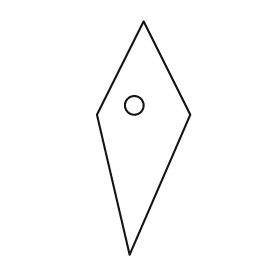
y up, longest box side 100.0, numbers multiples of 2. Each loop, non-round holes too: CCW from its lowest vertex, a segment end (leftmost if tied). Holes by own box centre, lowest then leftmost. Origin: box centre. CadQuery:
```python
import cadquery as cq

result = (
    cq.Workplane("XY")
    .moveTo(-6.0, -50.0)
    .lineTo(20.0, 10.0)
    .lineTo(0.0, 50.0)
    .lineTo(-20.0, 10.0)
    .close()
    .moveTo(-4.0, 14.0)
    .circle(4.0)
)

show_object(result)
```